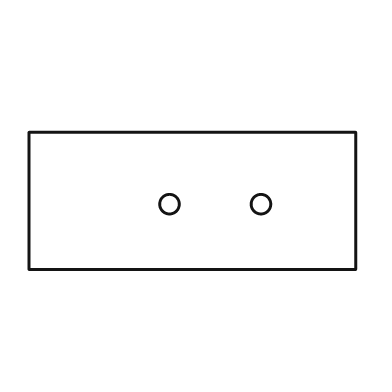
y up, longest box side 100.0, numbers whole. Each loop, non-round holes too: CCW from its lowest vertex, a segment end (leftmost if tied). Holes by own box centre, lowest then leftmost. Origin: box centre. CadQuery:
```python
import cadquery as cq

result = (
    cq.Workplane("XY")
    .moveTo(-50.0, -21.0)
    .lineTo(50.0, -21.0)
    .lineTo(50.0, 21.0)
    .lineTo(-50.0, 21.0)
    .close()
    .moveTo(-7.0, -1.0)
    .circle(3.0)
    .moveTo(21.0, -1.0)
    .circle(3.0)
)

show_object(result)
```